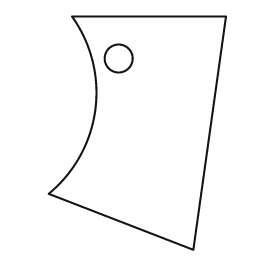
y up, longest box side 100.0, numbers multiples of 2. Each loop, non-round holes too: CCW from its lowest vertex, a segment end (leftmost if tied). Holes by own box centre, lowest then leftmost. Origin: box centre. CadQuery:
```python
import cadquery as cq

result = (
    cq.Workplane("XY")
    .moveTo(24.0, -50.0)
    .lineTo(38.0, 50.0)
    .lineTo(-28.0, 50.0)
    .threePointArc((-18.0, 10.0), (-38.0, -26.0))
    .close()
    .moveTo(-8.0, 32.0)
    .circle(6.0)
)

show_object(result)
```